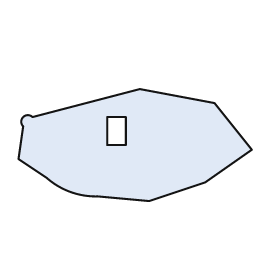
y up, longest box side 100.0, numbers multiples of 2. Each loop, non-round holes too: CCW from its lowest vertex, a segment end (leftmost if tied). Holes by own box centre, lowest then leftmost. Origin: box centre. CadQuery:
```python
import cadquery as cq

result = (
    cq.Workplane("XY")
    .moveTo(6.0, -24.0)
    .lineTo(30.0, -16.0)
    .lineTo(50.0, -2.0)
    .lineTo(34.0, 18.0)
    .lineTo(2.0, 24.0)
    .lineTo(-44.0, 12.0)
    .threePointArc((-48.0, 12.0), (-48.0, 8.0))
    .lineTo(-50.0, -6.0)
    .lineTo(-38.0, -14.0)
    .threePointArc((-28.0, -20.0), (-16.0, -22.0))
    .close()
    .moveTo(-12.0, 0.0)
    .lineTo(-4.0, 0.0)
    .lineTo(-4.0, 12.0)
    .lineTo(-12.0, 12.0)
    .close()
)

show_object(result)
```